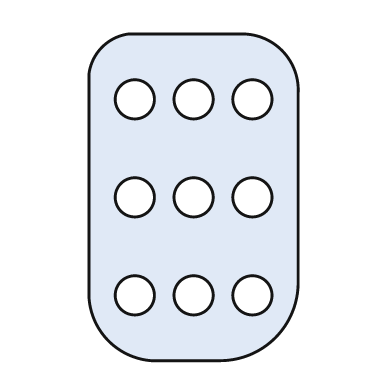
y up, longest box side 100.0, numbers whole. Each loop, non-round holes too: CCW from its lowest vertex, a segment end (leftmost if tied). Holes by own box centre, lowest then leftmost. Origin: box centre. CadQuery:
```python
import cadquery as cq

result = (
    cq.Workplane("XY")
    .moveTo(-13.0, -50.0)
    .lineTo(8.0, -50.0)
    .threePointArc((25.0, -43.0), (32.0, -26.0))
    .lineTo(32.0, 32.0)
    .threePointArc((27.0, 45.0), (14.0, 50.0))
    .lineTo(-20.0, 50.0)
    .threePointArc((-28.0, 46.0), (-32.0, 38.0))
    .lineTo(-32.0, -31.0)
    .threePointArc((-26.0, -44.0), (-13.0, -50.0))
    .close()
    .moveTo(-18.0, -30.0)
    .circle(6.0)
    .moveTo(0.0, -30.0)
    .circle(6.0)
    .moveTo(18.0, -30.0)
    .circle(6.0)
    .moveTo(-18.0, 0.0)
    .circle(6.0)
    .moveTo(0.0, 0.0)
    .circle(6.0)
    .moveTo(18.0, 0.0)
    .circle(6.0)
    .moveTo(-18.0, 30.0)
    .circle(6.0)
    .moveTo(0.0, 30.0)
    .circle(6.0)
    .moveTo(18.0, 30.0)
    .circle(6.0)
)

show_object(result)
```